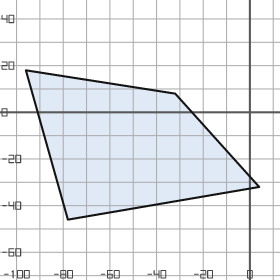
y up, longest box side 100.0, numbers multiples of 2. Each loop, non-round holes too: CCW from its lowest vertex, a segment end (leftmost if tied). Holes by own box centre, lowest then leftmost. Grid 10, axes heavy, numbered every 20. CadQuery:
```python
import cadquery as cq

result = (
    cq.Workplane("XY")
    .moveTo(-78.0, -46.0)
    .lineTo(4.0, -32.0)
    .lineTo(-32.0, 8.0)
    .lineTo(-96.0, 18.0)
    .close()
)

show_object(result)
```